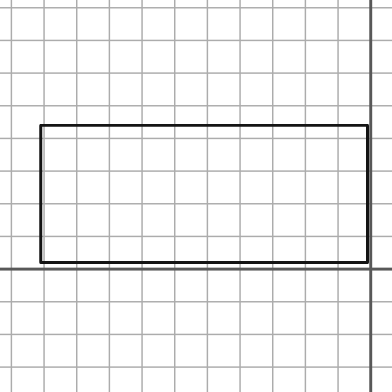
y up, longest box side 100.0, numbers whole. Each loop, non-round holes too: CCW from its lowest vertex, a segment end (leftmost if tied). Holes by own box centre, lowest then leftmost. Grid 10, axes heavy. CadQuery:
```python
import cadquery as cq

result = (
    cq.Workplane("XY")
    .moveTo(-101.0, 2.0)
    .lineTo(-1.0, 2.0)
    .lineTo(-1.0, 44.0)
    .lineTo(-101.0, 44.0)
    .close()
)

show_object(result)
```